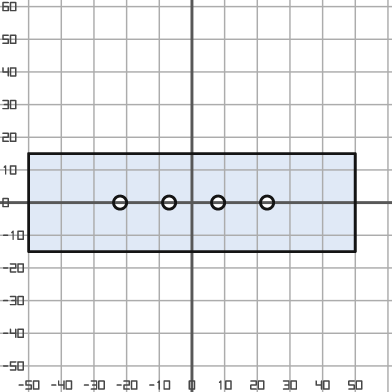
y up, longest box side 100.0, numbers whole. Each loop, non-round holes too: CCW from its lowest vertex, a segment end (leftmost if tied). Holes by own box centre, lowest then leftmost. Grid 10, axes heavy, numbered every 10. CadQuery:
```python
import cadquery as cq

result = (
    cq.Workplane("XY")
    .moveTo(-50.0, -15.0)
    .lineTo(50.0, -15.0)
    .lineTo(50.0, 15.0)
    .lineTo(-50.0, 15.0)
    .close()
    .moveTo(-22.0, 0.0)
    .circle(2.0)
    .moveTo(-7.0, 0.0)
    .circle(2.0)
    .moveTo(8.0, 0.0)
    .circle(2.0)
    .moveTo(23.0, 0.0)
    .circle(2.0)
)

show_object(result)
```